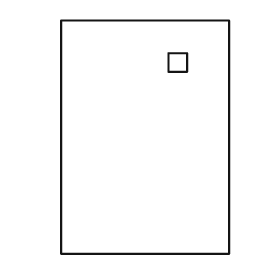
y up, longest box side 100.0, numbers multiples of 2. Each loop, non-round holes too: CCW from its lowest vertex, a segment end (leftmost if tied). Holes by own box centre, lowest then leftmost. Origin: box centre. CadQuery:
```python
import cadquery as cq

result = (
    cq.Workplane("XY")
    .moveTo(-36.0, -50.0)
    .lineTo(36.0, -50.0)
    .lineTo(36.0, 50.0)
    .lineTo(-36.0, 50.0)
    .close()
    .moveTo(10.0, 28.0)
    .lineTo(18.0, 28.0)
    .lineTo(18.0, 36.0)
    .lineTo(10.0, 36.0)
    .close()
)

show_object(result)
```